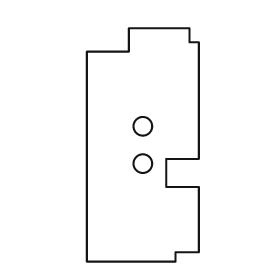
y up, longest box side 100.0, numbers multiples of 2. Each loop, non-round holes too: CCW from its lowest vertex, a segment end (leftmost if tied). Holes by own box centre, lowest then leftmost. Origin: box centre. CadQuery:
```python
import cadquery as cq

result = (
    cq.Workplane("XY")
    .moveTo(-24.0, -50.0)
    .lineTo(14.0, -50.0)
    .lineTo(14.0, -46.0)
    .lineTo(24.0, -46.0)
    .lineTo(24.0, -18.0)
    .lineTo(10.0, -18.0)
    .lineTo(10.0, -6.0)
    .lineTo(24.0, -6.0)
    .lineTo(24.0, 44.0)
    .lineTo(20.0, 44.0)
    .lineTo(20.0, 50.0)
    .lineTo(-6.0, 50.0)
    .lineTo(-6.0, 40.0)
    .lineTo(-24.0, 40.0)
    .close()
    .moveTo(0.0, -8.0)
    .circle(4.0)
    .moveTo(0.0, 8.0)
    .circle(4.0)
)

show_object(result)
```